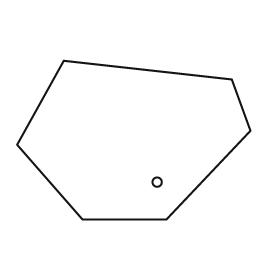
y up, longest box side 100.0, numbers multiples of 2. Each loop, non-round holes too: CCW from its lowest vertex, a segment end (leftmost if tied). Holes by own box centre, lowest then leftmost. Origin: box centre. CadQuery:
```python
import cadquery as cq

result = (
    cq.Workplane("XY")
    .moveTo(-22.0, -34.0)
    .lineTo(14.0, -34.0)
    .lineTo(50.0, 4.0)
    .lineTo(42.0, 26.0)
    .lineTo(-30.0, 34.0)
    .lineTo(-50.0, -2.0)
    .close()
    .moveTo(10.0, -18.0)
    .circle(2.0)
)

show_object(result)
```